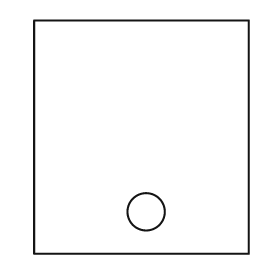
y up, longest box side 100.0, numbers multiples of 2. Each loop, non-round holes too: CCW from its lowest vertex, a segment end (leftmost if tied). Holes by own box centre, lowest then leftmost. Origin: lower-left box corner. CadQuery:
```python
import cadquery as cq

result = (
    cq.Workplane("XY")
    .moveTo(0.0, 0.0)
    .lineTo(92.0, 0.0)
    .lineTo(92.0, 100.0)
    .lineTo(0.0, 100.0)
    .close()
    .moveTo(48.0, 18.0)
    .circle(8.0)
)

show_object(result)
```